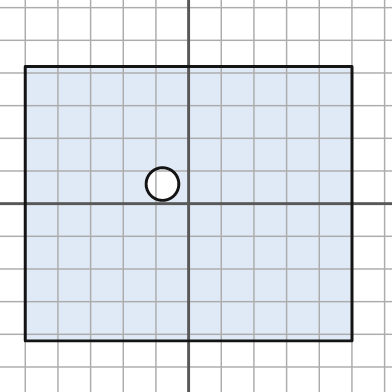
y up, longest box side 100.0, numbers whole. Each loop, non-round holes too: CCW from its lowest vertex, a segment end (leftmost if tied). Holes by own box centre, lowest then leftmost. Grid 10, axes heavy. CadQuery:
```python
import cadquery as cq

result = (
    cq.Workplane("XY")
    .moveTo(-50.0, -42.0)
    .lineTo(50.0, -42.0)
    .lineTo(50.0, 42.0)
    .lineTo(-50.0, 42.0)
    .close()
    .moveTo(-8.0, 6.0)
    .circle(5.0)
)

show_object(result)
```